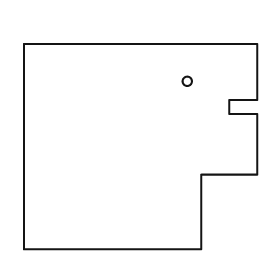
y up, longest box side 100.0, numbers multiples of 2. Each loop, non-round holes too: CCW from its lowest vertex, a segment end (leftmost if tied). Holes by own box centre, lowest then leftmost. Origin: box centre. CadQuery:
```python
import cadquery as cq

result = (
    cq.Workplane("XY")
    .moveTo(-50.0, -44.0)
    .lineTo(26.0, -44.0)
    .lineTo(26.0, -12.0)
    .lineTo(50.0, -12.0)
    .lineTo(50.0, 14.0)
    .lineTo(38.0, 14.0)
    .lineTo(38.0, 20.0)
    .lineTo(50.0, 20.0)
    .lineTo(50.0, 44.0)
    .lineTo(-50.0, 44.0)
    .close()
    .moveTo(20.0, 28.0)
    .circle(2.0)
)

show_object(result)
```